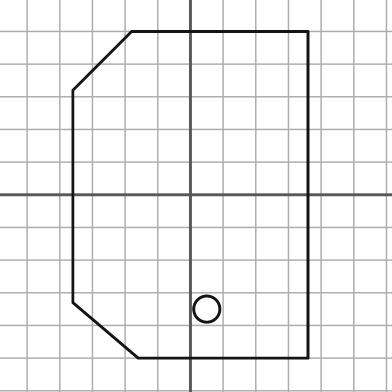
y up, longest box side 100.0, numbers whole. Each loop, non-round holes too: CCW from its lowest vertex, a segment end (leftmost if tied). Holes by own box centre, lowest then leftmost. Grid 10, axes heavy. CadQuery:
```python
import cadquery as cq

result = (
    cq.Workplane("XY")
    .moveTo(-16.0, -50.0)
    .lineTo(36.0, -50.0)
    .lineTo(36.0, 50.0)
    .lineTo(-18.0, 50.0)
    .lineTo(-36.0, 32.0)
    .lineTo(-36.0, -33.0)
    .close()
    .moveTo(5.0, -35.0)
    .circle(4.0)
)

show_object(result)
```